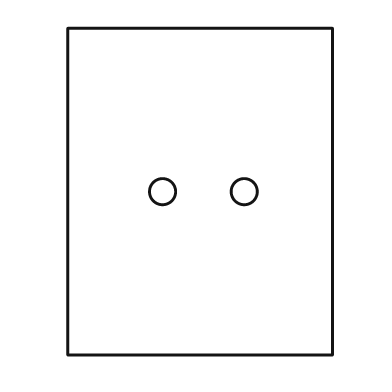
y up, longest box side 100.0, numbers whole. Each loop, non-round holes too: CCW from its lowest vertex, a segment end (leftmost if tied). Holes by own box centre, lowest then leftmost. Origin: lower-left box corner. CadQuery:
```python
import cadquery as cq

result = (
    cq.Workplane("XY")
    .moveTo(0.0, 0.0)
    .lineTo(81.0, 0.0)
    .lineTo(81.0, 100.0)
    .lineTo(0.0, 100.0)
    .close()
    .moveTo(29.0, 50.0)
    .circle(4.0)
    .moveTo(54.0, 50.0)
    .circle(4.0)
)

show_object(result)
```